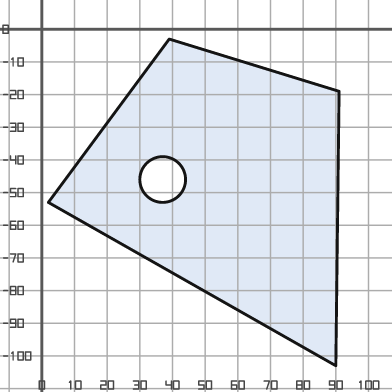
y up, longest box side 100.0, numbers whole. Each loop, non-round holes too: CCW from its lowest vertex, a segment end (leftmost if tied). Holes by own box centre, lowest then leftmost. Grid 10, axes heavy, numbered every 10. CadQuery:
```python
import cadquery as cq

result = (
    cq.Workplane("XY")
    .moveTo(90.0, -103.0)
    .lineTo(91.0, -19.0)
    .lineTo(39.0, -3.0)
    .lineTo(2.0, -53.0)
    .close()
    .moveTo(37.0, -46.0)
    .circle(7.0)
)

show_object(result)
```